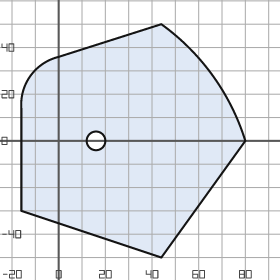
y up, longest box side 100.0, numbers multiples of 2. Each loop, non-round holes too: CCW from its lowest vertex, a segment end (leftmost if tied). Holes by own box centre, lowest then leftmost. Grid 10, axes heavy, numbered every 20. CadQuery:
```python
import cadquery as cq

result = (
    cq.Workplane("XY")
    .moveTo(44.0, -50.0)
    .lineTo(80.0, 0.0)
    .threePointArc((66.0, 28.0), (44.0, 50.0))
    .lineTo(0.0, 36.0)
    .threePointArc((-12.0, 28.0), (-16.0, 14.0))
    .lineTo(-16.0, -30.0)
    .close()
    .moveTo(16.0, 0.0)
    .circle(4.0)
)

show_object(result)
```